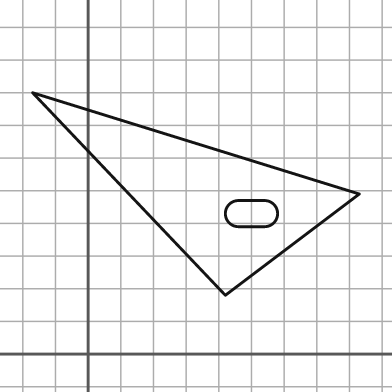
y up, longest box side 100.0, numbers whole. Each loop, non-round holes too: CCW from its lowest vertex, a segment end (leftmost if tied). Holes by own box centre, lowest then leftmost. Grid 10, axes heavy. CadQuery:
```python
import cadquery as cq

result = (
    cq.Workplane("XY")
    .moveTo(42.0, 18.0)
    .lineTo(83.0, 49.0)
    .lineTo(-17.0, 80.0)
    .close()
    .moveTo(46.0, 39.0)
    .lineTo(54.0, 39.0)
    .threePointArc((58.0, 43.0), (54.0, 47.0))
    .lineTo(46.0, 47.0)
    .threePointArc((42.0, 43.0), (46.0, 39.0))
    .close()
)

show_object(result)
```